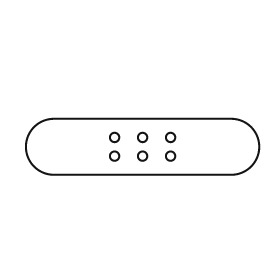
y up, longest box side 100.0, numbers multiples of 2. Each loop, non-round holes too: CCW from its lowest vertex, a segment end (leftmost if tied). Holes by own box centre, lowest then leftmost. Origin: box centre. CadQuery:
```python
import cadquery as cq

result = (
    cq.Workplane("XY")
    .moveTo(-38.0, -12.0)
    .lineTo(38.0, -12.0)
    .threePointArc((50.0, 0.0), (38.0, 12.0))
    .lineTo(-38.0, 12.0)
    .threePointArc((-50.0, 0.0), (-38.0, -12.0))
    .close()
    .moveTo(-12.0, -4.0)
    .circle(2.0)
    .moveTo(0.0, -4.0)
    .circle(2.0)
    .moveTo(12.0, -4.0)
    .circle(2.0)
    .moveTo(-12.0, 4.0)
    .circle(2.0)
    .moveTo(0.0, 4.0)
    .circle(2.0)
    .moveTo(12.0, 4.0)
    .circle(2.0)
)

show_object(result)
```